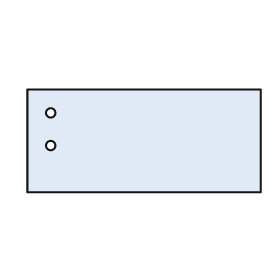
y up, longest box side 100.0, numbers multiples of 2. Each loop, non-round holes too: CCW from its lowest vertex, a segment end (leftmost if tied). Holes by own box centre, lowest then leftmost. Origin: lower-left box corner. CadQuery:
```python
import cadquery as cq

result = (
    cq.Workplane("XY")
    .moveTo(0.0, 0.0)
    .lineTo(100.0, 0.0)
    .lineTo(100.0, 44.0)
    .lineTo(0.0, 44.0)
    .close()
    .moveTo(10.0, 20.0)
    .circle(2.0)
    .moveTo(10.0, 34.0)
    .circle(2.0)
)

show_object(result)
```